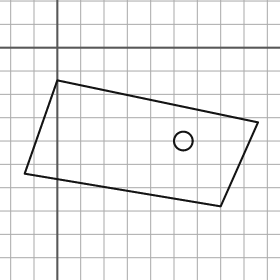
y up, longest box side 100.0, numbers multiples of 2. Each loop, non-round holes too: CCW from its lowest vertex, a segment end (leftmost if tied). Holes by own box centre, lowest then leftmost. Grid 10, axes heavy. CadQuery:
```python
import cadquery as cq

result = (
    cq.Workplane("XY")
    .moveTo(70.0, -68.0)
    .lineTo(86.0, -32.0)
    .lineTo(0.0, -14.0)
    .lineTo(-14.0, -54.0)
    .close()
    .moveTo(54.0, -40.0)
    .circle(4.0)
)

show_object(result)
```